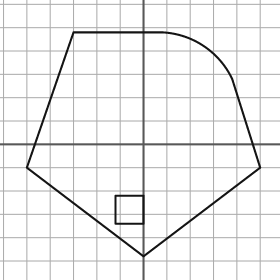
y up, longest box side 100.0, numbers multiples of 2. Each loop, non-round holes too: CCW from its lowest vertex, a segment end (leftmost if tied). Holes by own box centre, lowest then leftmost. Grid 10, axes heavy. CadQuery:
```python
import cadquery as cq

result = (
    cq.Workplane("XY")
    .moveTo(0.0, -48.0)
    .lineTo(50.0, -10.0)
    .lineTo(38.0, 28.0)
    .threePointArc((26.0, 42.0), (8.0, 48.0))
    .lineTo(-30.0, 48.0)
    .lineTo(-50.0, -10.0)
    .close()
    .moveTo(-12.0, -34.0)
    .lineTo(0.0, -34.0)
    .lineTo(0.0, -22.0)
    .lineTo(-12.0, -22.0)
    .close()
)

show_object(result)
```